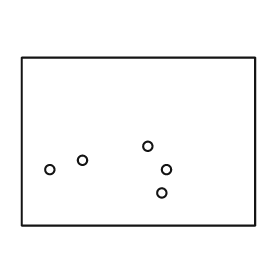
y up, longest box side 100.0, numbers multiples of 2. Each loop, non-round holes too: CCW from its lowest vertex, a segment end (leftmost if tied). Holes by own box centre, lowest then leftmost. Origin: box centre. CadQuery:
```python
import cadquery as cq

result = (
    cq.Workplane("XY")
    .moveTo(-50.0, -36.0)
    .lineTo(50.0, -36.0)
    .lineTo(50.0, 36.0)
    .lineTo(-50.0, 36.0)
    .close()
    .moveTo(10.0, -22.0)
    .circle(2.0)
    .moveTo(-38.0, -12.0)
    .circle(2.0)
    .moveTo(12.0, -12.0)
    .circle(2.0)
    .moveTo(-24.0, -8.0)
    .circle(2.0)
    .moveTo(4.0, -2.0)
    .circle(2.0)
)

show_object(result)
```